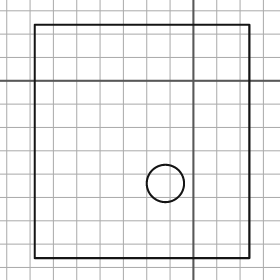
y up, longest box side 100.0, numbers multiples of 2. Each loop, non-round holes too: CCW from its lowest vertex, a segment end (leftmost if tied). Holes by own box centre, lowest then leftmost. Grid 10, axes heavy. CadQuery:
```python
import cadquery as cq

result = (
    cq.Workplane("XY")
    .moveTo(-68.0, -76.0)
    .lineTo(24.0, -76.0)
    .lineTo(24.0, 24.0)
    .lineTo(-68.0, 24.0)
    .close()
    .moveTo(-12.0, -44.0)
    .circle(8.0)
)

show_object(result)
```